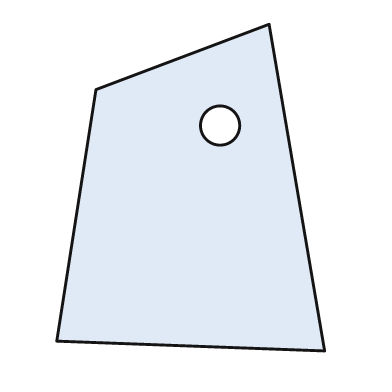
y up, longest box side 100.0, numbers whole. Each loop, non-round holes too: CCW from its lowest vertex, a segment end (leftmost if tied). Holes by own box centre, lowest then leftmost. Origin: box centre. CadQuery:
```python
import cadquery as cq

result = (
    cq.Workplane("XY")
    .moveTo(41.0, -50.0)
    .lineTo(24.0, 50.0)
    .lineTo(-29.0, 30.0)
    .lineTo(-41.0, -47.0)
    .close()
    .moveTo(9.0, 19.0)
    .circle(6.0)
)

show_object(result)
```